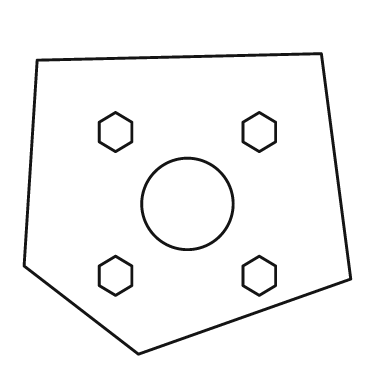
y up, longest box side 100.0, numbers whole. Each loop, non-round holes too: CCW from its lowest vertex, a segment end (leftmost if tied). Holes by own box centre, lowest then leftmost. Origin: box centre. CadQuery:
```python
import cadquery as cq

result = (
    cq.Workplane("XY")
    .moveTo(-15.0, -46.0)
    .lineTo(50.0, -23.0)
    .lineTo(41.0, 46.0)
    .lineTo(-46.0, 44.0)
    .lineTo(-50.0, -19.0)
    .close()
    .moveTo(-22.0, -28.0)
    .lineTo(-17.0, -25.0)
    .lineTo(-17.0, -19.0)
    .lineTo(-22.0, -16.0)
    .lineTo(-27.0, -19.0)
    .lineTo(-27.0, -25.0)
    .close()
    .moveTo(22.0, -28.0)
    .lineTo(27.0, -25.0)
    .lineTo(27.0, -19.0)
    .lineTo(22.0, -16.0)
    .lineTo(17.0, -19.0)
    .lineTo(17.0, -25.0)
    .close()
    .moveTo(0.0, 0.0)
    .circle(14.0)
    .moveTo(-22.0, 16.0)
    .lineTo(-17.0, 19.0)
    .lineTo(-17.0, 25.0)
    .lineTo(-22.0, 28.0)
    .lineTo(-27.0, 25.0)
    .lineTo(-27.0, 19.0)
    .close()
    .moveTo(22.0, 16.0)
    .lineTo(27.0, 19.0)
    .lineTo(27.0, 25.0)
    .lineTo(22.0, 28.0)
    .lineTo(17.0, 25.0)
    .lineTo(17.0, 19.0)
    .close()
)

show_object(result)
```